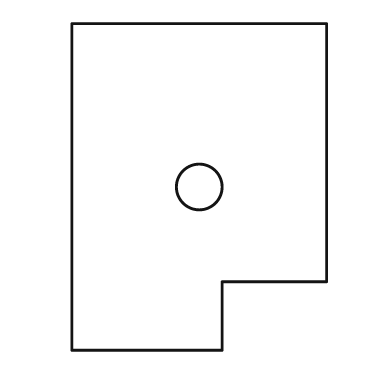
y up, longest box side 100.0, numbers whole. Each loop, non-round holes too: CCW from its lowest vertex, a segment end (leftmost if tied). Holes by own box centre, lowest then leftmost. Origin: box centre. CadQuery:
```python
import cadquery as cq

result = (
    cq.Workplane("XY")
    .moveTo(-39.0, -50.0)
    .lineTo(7.0, -50.0)
    .lineTo(7.0, -29.0)
    .lineTo(39.0, -29.0)
    .lineTo(39.0, 50.0)
    .lineTo(-39.0, 50.0)
    .close()
    .moveTo(0.0, 0.0)
    .circle(7.0)
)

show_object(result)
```